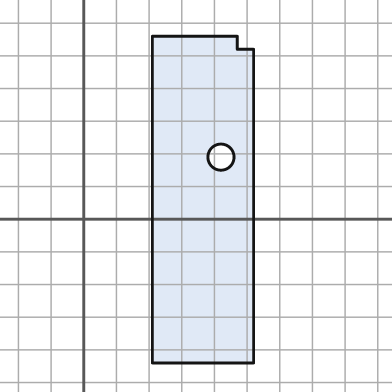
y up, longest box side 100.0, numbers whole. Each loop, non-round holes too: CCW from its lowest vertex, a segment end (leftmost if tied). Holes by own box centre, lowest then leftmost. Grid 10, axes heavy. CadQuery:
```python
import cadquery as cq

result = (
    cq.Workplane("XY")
    .moveTo(21.0, -44.0)
    .lineTo(52.0, -44.0)
    .lineTo(52.0, 52.0)
    .lineTo(47.0, 52.0)
    .lineTo(47.0, 56.0)
    .lineTo(21.0, 56.0)
    .close()
    .moveTo(42.0, 19.0)
    .circle(4.0)
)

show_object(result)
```